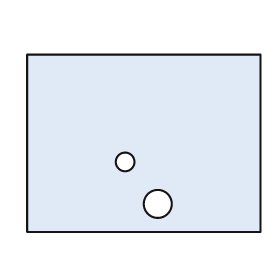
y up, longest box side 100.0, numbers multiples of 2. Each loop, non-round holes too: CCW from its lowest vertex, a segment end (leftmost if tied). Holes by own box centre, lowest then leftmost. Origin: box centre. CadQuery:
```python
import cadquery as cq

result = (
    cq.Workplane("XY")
    .moveTo(-50.0, -38.0)
    .lineTo(50.0, -38.0)
    .lineTo(50.0, 38.0)
    .lineTo(-50.0, 38.0)
    .close()
    .moveTo(6.0, -26.0)
    .circle(6.0)
    .moveTo(-8.0, -8.0)
    .circle(4.0)
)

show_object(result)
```